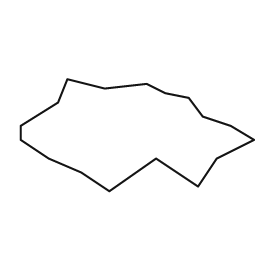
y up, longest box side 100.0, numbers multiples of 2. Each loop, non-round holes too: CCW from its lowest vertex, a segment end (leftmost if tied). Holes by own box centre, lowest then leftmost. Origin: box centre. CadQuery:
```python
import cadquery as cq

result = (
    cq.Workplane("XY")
    .moveTo(-12.0, -24.0)
    .lineTo(8.0, -10.0)
    .lineTo(26.0, -22.0)
    .lineTo(34.0, -10.0)
    .lineTo(50.0, -2.0)
    .lineTo(40.0, 4.0)
    .lineTo(28.0, 8.0)
    .lineTo(22.0, 16.0)
    .lineTo(12.0, 18.0)
    .lineTo(4.0, 22.0)
    .lineTo(-14.0, 20.0)
    .lineTo(-30.0, 24.0)
    .lineTo(-34.0, 14.0)
    .lineTo(-50.0, 4.0)
    .lineTo(-50.0, -2.0)
    .lineTo(-38.0, -10.0)
    .lineTo(-24.0, -16.0)
    .close()
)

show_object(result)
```